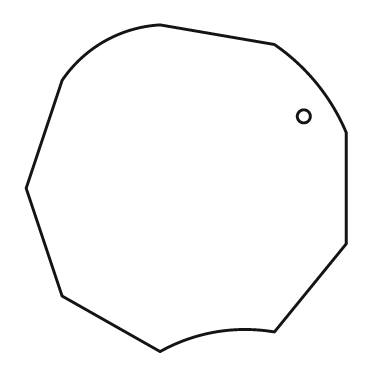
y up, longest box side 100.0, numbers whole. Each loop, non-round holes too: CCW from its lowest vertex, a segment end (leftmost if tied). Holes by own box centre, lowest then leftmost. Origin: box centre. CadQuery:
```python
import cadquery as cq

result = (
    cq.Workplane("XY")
    .moveTo(-8.0, -50.0)
    .threePointArc((9.0, -44.0), (27.0, -44.0))
    .lineTo(49.0, -17.0)
    .lineTo(49.0, 17.0)
    .threePointArc((40.0, 32.0), (27.0, 44.0))
    .lineTo(-8.0, 50.0)
    .threePointArc((-25.0, 45.0), (-38.0, 33.0))
    .lineTo(-49.0, 0.0)
    .lineTo(-38.0, -33.0)
    .close()
    .moveTo(36.0, 22.0)
    .circle(2.0)
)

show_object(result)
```